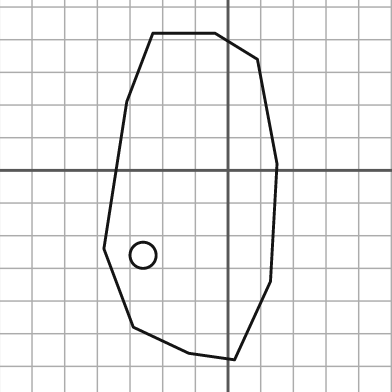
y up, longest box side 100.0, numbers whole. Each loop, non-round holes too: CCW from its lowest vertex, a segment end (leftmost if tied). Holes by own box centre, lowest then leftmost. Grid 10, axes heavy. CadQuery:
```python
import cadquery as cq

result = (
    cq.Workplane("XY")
    .moveTo(2.0, -58.0)
    .lineTo(13.0, -34.0)
    .lineTo(15.0, 2.0)
    .lineTo(9.0, 34.0)
    .lineTo(-4.0, 42.0)
    .lineTo(-23.0, 42.0)
    .lineTo(-31.0, 21.0)
    .lineTo(-38.0, -24.0)
    .lineTo(-29.0, -48.0)
    .lineTo(-12.0, -56.0)
    .close()
    .moveTo(-26.0, -26.0)
    .circle(4.0)
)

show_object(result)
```